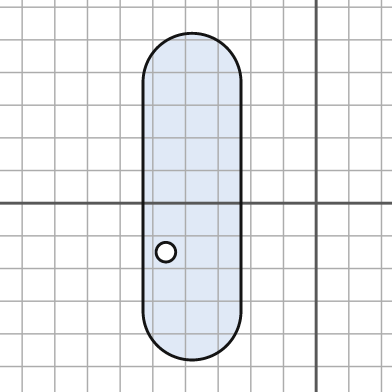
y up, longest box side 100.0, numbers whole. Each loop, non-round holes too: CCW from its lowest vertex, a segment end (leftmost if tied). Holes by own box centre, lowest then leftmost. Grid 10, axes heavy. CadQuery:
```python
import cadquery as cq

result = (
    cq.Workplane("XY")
    .moveTo(-53.0, -33.0)
    .threePointArc((-38.0, -48.0), (-23.0, -33.0))
    .lineTo(-23.0, 37.0)
    .threePointArc((-38.0, 52.0), (-53.0, 37.0))
    .close()
    .moveTo(-46.0, -15.0)
    .circle(3.0)
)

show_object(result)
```